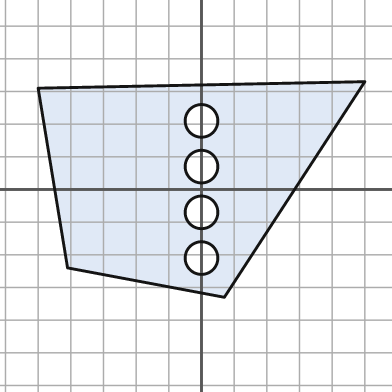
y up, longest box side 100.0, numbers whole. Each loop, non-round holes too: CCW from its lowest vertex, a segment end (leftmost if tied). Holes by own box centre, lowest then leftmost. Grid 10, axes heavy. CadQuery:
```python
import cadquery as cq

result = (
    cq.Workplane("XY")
    .moveTo(7.0, -33.0)
    .lineTo(50.0, 33.0)
    .lineTo(-50.0, 31.0)
    .lineTo(-41.0, -24.0)
    .close()
    .moveTo(0.0, -21.0)
    .circle(5.0)
    .moveTo(0.0, -7.0)
    .circle(5.0)
    .moveTo(0.0, 7.0)
    .circle(5.0)
    .moveTo(0.0, 21.0)
    .circle(5.0)
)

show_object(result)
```